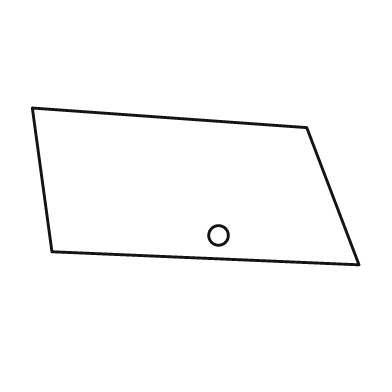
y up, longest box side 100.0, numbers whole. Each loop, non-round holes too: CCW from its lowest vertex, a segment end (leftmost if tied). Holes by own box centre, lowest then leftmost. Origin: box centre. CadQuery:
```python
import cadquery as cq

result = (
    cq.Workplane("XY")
    .moveTo(50.0, -24.0)
    .lineTo(34.0, 18.0)
    .lineTo(-50.0, 24.0)
    .lineTo(-44.0, -20.0)
    .close()
    .moveTo(7.0, -15.0)
    .circle(3.0)
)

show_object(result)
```